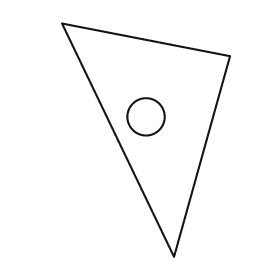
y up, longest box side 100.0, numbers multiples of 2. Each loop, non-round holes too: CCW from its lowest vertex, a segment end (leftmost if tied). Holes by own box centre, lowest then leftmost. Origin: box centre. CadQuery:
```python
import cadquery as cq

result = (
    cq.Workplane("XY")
    .moveTo(12.0, -50.0)
    .lineTo(36.0, 36.0)
    .lineTo(-36.0, 50.0)
    .close()
    .moveTo(0.0, 10.0)
    .circle(8.0)
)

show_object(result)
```